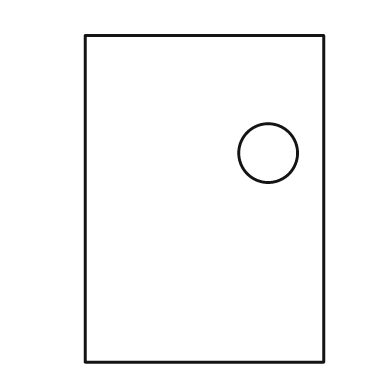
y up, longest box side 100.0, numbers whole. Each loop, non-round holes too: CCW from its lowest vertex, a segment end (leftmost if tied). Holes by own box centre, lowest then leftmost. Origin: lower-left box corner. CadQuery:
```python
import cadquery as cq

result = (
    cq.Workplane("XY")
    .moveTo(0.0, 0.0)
    .lineTo(73.0, 0.0)
    .lineTo(73.0, 100.0)
    .lineTo(0.0, 100.0)
    .close()
    .moveTo(56.0, 64.0)
    .circle(9.0)
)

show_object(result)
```